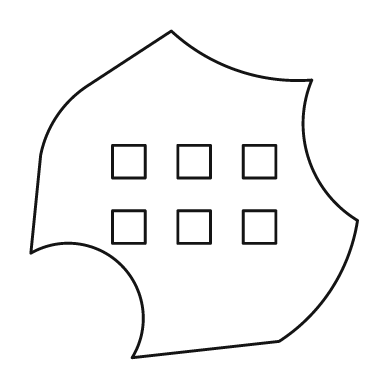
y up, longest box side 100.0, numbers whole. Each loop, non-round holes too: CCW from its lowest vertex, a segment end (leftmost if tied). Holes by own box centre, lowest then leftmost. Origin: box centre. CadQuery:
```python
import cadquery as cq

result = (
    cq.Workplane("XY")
    .moveTo(-19.0, -50.0)
    .lineTo(26.0, -45.0)
    .threePointArc((42.0, -29.0), (50.0, -8.0))
    .threePointArc((35.0, 11.0), (36.0, 35.0))
    .threePointArc((13.0, 38.0), (-7.0, 50.0))
    .lineTo(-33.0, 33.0)
    .threePointArc((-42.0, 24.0), (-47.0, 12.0))
    .lineTo(-50.0, -18.0)
    .threePointArc((-22.0, -22.0), (-19.0, -50.0))
    .close()
    .moveTo(-25.0, -15.0)
    .lineTo(-15.0, -15.0)
    .lineTo(-15.0, -5.0)
    .lineTo(-25.0, -5.0)
    .close()
    .moveTo(-5.0, -15.0)
    .lineTo(5.0, -15.0)
    .lineTo(5.0, -5.0)
    .lineTo(-5.0, -5.0)
    .close()
    .moveTo(15.0, -15.0)
    .lineTo(25.0, -15.0)
    .lineTo(25.0, -5.0)
    .lineTo(15.0, -5.0)
    .close()
    .moveTo(-25.0, 5.0)
    .lineTo(-15.0, 5.0)
    .lineTo(-15.0, 15.0)
    .lineTo(-25.0, 15.0)
    .close()
    .moveTo(-5.0, 5.0)
    .lineTo(5.0, 5.0)
    .lineTo(5.0, 15.0)
    .lineTo(-5.0, 15.0)
    .close()
    .moveTo(15.0, 5.0)
    .lineTo(25.0, 5.0)
    .lineTo(25.0, 15.0)
    .lineTo(15.0, 15.0)
    .close()
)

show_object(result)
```